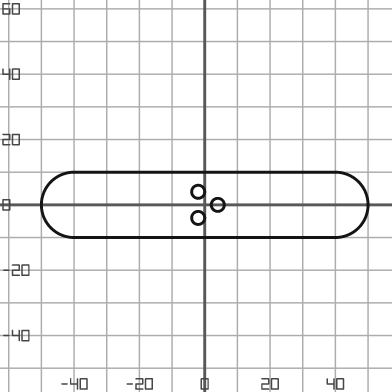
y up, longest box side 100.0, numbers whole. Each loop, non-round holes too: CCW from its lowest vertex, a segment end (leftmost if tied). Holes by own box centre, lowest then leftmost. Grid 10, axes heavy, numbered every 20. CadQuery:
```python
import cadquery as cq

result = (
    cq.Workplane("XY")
    .moveTo(-40.0, -10.0)
    .lineTo(40.0, -10.0)
    .threePointArc((50.0, 0.0), (40.0, 10.0))
    .lineTo(-40.0, 10.0)
    .threePointArc((-50.0, 0.0), (-40.0, -10.0))
    .close()
    .moveTo(-2.0, -4.0)
    .circle(2.0)
    .moveTo(4.0, 0.0)
    .circle(2.0)
    .moveTo(-2.0, 4.0)
    .circle(2.0)
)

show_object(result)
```